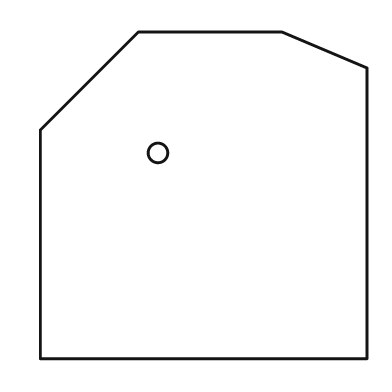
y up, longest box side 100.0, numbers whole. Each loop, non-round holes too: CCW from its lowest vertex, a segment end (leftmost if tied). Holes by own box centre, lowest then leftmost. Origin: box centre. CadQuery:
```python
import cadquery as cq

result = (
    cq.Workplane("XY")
    .moveTo(-50.0, -50.0)
    .lineTo(50.0, -50.0)
    .lineTo(50.0, 39.0)
    .lineTo(24.0, 50.0)
    .lineTo(-20.0, 50.0)
    .lineTo(-50.0, 20.0)
    .close()
    .moveTo(-14.0, 13.0)
    .circle(3.0)
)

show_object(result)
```